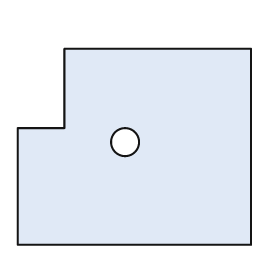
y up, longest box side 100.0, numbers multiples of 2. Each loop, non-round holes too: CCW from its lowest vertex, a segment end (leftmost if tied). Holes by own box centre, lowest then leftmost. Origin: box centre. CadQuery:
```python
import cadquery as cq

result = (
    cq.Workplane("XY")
    .moveTo(-50.0, -42.0)
    .lineTo(50.0, -42.0)
    .lineTo(50.0, 42.0)
    .lineTo(-30.0, 42.0)
    .lineTo(-30.0, 8.0)
    .lineTo(-50.0, 8.0)
    .close()
    .moveTo(-4.0, 2.0)
    .circle(6.0)
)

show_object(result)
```